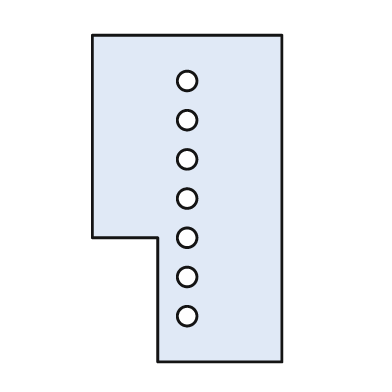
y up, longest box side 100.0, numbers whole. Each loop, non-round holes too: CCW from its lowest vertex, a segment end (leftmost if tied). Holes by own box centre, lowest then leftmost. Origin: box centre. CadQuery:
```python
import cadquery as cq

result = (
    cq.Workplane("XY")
    .moveTo(-9.0, -50.0)
    .lineTo(29.0, -50.0)
    .lineTo(29.0, 50.0)
    .lineTo(-29.0, 50.0)
    .lineTo(-29.0, -12.0)
    .lineTo(-9.0, -12.0)
    .close()
    .moveTo(0.0, -36.0)
    .circle(3.0)
    .moveTo(0.0, -24.0)
    .circle(3.0)
    .moveTo(0.0, -12.0)
    .circle(3.0)
    .moveTo(0.0, 0.0)
    .circle(3.0)
    .moveTo(0.0, 12.0)
    .circle(3.0)
    .moveTo(0.0, 24.0)
    .circle(3.0)
    .moveTo(0.0, 36.0)
    .circle(3.0)
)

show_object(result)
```